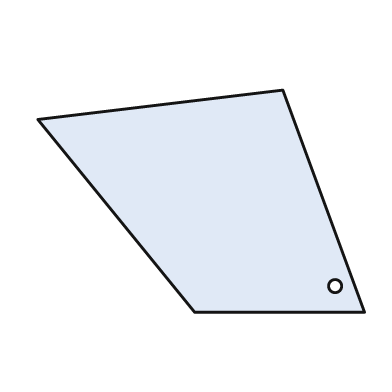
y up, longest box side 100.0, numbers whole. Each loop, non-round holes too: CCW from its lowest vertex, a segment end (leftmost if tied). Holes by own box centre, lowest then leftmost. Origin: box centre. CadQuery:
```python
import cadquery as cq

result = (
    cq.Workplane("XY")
    .moveTo(-2.0, -34.0)
    .lineTo(50.0, -34.0)
    .lineTo(25.0, 34.0)
    .lineTo(-50.0, 25.0)
    .close()
    .moveTo(41.0, -26.0)
    .circle(2.0)
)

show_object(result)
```